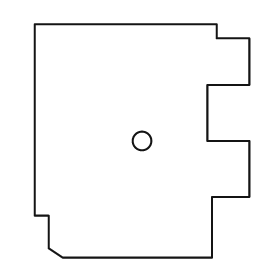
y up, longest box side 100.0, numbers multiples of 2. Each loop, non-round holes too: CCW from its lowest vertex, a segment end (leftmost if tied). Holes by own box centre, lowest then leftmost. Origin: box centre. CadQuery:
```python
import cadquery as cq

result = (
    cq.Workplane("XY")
    .moveTo(-34.0, -50.0)
    .lineTo(30.0, -50.0)
    .lineTo(30.0, -24.0)
    .lineTo(46.0, -24.0)
    .lineTo(46.0, 0.0)
    .lineTo(28.0, 0.0)
    .lineTo(28.0, 24.0)
    .lineTo(46.0, 24.0)
    .lineTo(46.0, 44.0)
    .lineTo(32.0, 44.0)
    .lineTo(32.0, 50.0)
    .lineTo(-46.0, 50.0)
    .lineTo(-46.0, -32.0)
    .lineTo(-40.0, -32.0)
    .lineTo(-40.0, -46.0)
    .close()
    .moveTo(0.0, 0.0)
    .circle(4.0)
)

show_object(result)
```